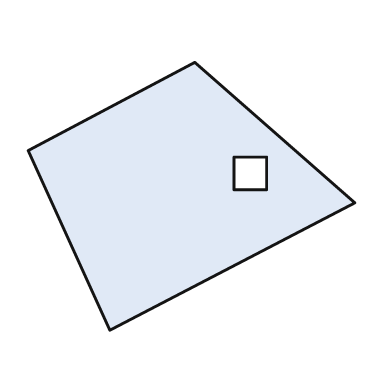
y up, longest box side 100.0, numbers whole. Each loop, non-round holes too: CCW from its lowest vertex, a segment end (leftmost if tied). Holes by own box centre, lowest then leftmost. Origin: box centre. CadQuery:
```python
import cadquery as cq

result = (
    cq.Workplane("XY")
    .moveTo(-25.0, -41.0)
    .lineTo(50.0, -2.0)
    .lineTo(1.0, 41.0)
    .lineTo(-50.0, 14.0)
    .close()
    .moveTo(13.0, 2.0)
    .lineTo(23.0, 2.0)
    .lineTo(23.0, 12.0)
    .lineTo(13.0, 12.0)
    .close()
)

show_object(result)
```